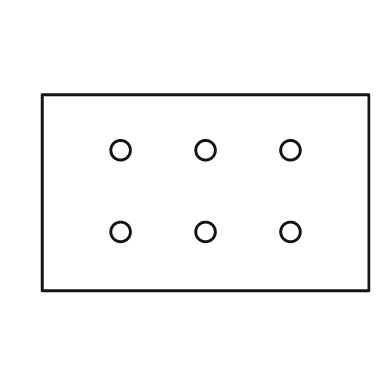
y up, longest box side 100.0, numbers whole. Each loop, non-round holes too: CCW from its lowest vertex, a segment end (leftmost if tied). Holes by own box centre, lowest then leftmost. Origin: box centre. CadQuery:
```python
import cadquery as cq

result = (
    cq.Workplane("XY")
    .moveTo(-50.0, -30.0)
    .lineTo(50.0, -30.0)
    .lineTo(50.0, 30.0)
    .lineTo(-50.0, 30.0)
    .close()
    .moveTo(-26.0, -12.0)
    .circle(3.0)
    .moveTo(0.0, -12.0)
    .circle(3.0)
    .moveTo(26.0, -12.0)
    .circle(3.0)
    .moveTo(-26.0, 13.0)
    .circle(3.0)
    .moveTo(0.0, 13.0)
    .circle(3.0)
    .moveTo(26.0, 13.0)
    .circle(3.0)
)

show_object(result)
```